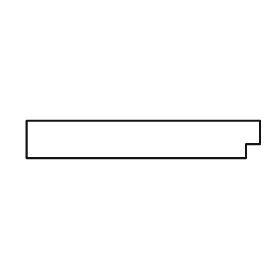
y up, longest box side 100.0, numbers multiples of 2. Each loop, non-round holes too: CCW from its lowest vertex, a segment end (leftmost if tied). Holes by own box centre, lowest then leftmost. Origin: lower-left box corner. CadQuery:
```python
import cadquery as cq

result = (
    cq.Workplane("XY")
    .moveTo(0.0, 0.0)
    .lineTo(94.0, 0.0)
    .lineTo(94.0, 6.0)
    .lineTo(100.0, 6.0)
    .lineTo(100.0, 16.0)
    .lineTo(0.0, 16.0)
    .close()
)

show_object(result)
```